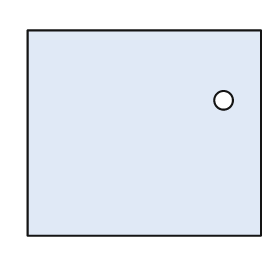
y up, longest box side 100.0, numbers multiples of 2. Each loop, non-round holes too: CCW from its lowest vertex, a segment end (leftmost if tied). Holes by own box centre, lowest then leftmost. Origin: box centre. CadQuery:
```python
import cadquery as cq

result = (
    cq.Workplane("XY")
    .moveTo(-50.0, -44.0)
    .lineTo(50.0, -44.0)
    .lineTo(50.0, 44.0)
    .lineTo(-50.0, 44.0)
    .close()
    .moveTo(34.0, 14.0)
    .circle(4.0)
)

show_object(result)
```